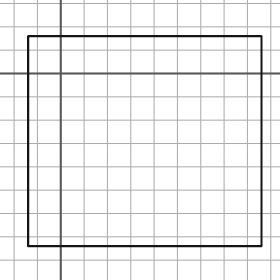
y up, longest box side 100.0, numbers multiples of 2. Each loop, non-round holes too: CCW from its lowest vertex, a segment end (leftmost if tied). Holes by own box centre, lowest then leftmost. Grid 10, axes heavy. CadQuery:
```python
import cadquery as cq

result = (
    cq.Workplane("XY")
    .moveTo(-14.0, -74.0)
    .lineTo(86.0, -74.0)
    .lineTo(86.0, 16.0)
    .lineTo(-14.0, 16.0)
    .close()
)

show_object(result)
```